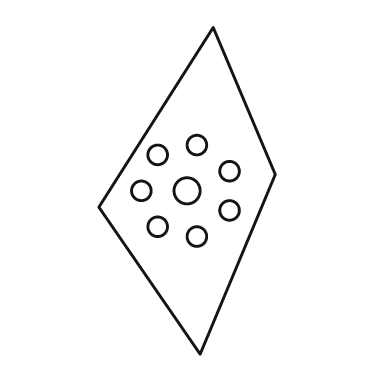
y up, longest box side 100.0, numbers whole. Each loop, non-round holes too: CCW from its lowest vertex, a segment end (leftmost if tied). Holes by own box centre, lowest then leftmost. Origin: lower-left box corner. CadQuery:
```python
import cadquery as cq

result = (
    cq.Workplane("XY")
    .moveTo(31.0, 0.0)
    .lineTo(54.0, 55.0)
    .lineTo(35.0, 100.0)
    .lineTo(0.0, 45.0)
    .close()
    .moveTo(30.0, 36.0)
    .circle(3.0)
    .moveTo(18.0, 39.0)
    .circle(3.0)
    .moveTo(40.0, 44.0)
    .circle(3.0)
    .moveTo(13.0, 50.0)
    .circle(3.0)
    .moveTo(27.0, 50.0)
    .circle(4.0)
    .moveTo(40.0, 56.0)
    .circle(3.0)
    .moveTo(18.0, 61.0)
    .circle(3.0)
    .moveTo(30.0, 64.0)
    .circle(3.0)
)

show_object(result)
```